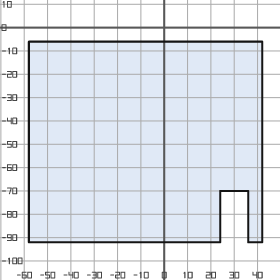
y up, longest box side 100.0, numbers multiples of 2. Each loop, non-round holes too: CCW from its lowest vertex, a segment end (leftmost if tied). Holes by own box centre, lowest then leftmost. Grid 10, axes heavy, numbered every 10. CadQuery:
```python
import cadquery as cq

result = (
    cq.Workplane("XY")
    .moveTo(-58.0, -92.0)
    .lineTo(24.0, -92.0)
    .lineTo(24.0, -70.0)
    .lineTo(36.0, -70.0)
    .lineTo(36.0, -92.0)
    .lineTo(42.0, -92.0)
    .lineTo(42.0, -6.0)
    .lineTo(-58.0, -6.0)
    .close()
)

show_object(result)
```